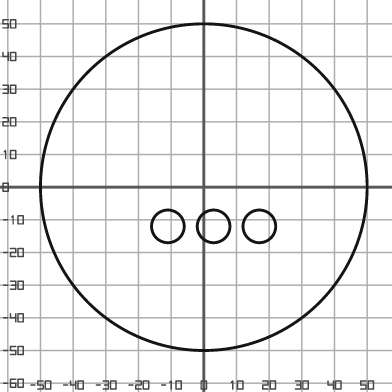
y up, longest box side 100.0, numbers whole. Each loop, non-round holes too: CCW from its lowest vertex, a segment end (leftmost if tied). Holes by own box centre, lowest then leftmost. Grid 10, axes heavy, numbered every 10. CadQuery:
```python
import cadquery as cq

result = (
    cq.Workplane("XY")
    .moveTo(0.0, 0.0)
    .circle(50.0)
    .moveTo(-11.0, -12.0)
    .circle(5.0)
    .moveTo(3.0, -12.0)
    .circle(5.0)
    .moveTo(17.0, -12.0)
    .circle(5.0)
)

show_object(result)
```